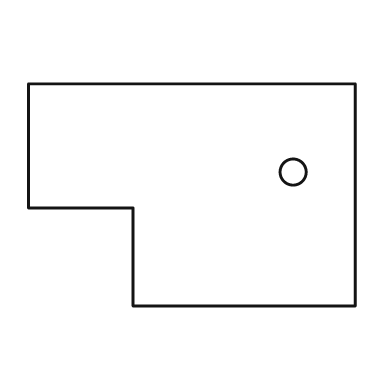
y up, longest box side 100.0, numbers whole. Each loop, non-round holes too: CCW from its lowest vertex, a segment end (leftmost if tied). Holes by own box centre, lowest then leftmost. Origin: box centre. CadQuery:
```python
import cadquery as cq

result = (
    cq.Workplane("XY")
    .moveTo(-18.0, -34.0)
    .lineTo(50.0, -34.0)
    .lineTo(50.0, 34.0)
    .lineTo(-50.0, 34.0)
    .lineTo(-50.0, -4.0)
    .lineTo(-18.0, -4.0)
    .close()
    .moveTo(31.0, 7.0)
    .circle(4.0)
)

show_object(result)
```